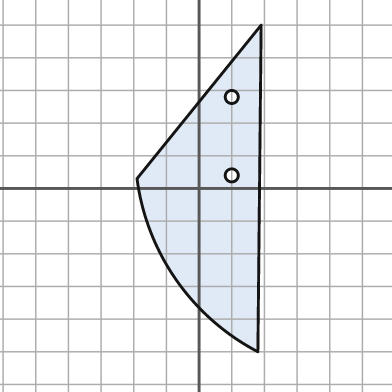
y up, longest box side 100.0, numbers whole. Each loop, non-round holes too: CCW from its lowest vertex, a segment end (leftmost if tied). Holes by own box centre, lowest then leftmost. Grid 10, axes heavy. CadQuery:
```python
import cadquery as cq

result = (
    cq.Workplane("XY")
    .moveTo(18.0, -50.0)
    .lineTo(19.0, 50.0)
    .lineTo(-19.0, 3.0)
    .threePointArc((-7.0, -28.0), (18.0, -50.0))
    .close()
    .moveTo(10.0, 4.0)
    .circle(2.0)
    .moveTo(10.0, 28.0)
    .circle(2.0)
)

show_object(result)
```